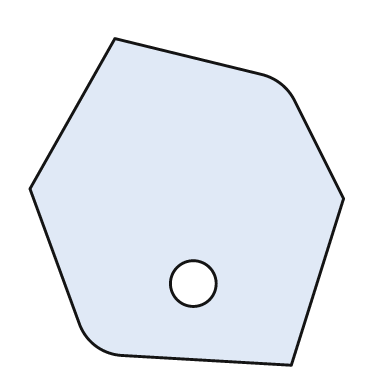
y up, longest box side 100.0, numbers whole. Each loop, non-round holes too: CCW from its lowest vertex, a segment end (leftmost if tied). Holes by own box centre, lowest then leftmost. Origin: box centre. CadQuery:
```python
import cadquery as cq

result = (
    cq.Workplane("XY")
    .moveTo(32.0, -50.0)
    .lineTo(48.0, 1.0)
    .lineTo(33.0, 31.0)
    .threePointArc((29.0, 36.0), (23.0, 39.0))
    .lineTo(-22.0, 50.0)
    .lineTo(-48.0, 4.0)
    .lineTo(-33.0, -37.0)
    .threePointArc((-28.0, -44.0), (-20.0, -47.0))
    .close()
    .moveTo(2.0, -25.0)
    .circle(7.0)
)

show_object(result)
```